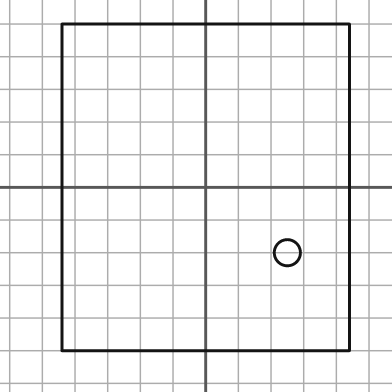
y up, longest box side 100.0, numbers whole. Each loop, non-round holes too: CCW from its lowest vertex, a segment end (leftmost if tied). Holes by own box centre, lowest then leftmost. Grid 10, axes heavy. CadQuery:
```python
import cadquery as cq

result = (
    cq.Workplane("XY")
    .moveTo(-44.0, -50.0)
    .lineTo(44.0, -50.0)
    .lineTo(44.0, 50.0)
    .lineTo(-44.0, 50.0)
    .close()
    .moveTo(25.0, -20.0)
    .circle(4.0)
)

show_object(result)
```